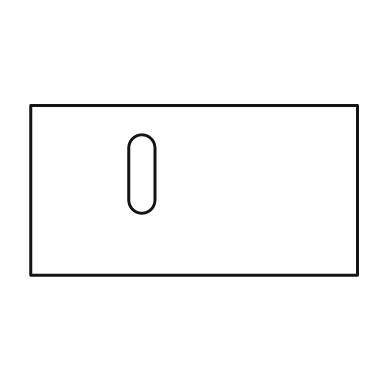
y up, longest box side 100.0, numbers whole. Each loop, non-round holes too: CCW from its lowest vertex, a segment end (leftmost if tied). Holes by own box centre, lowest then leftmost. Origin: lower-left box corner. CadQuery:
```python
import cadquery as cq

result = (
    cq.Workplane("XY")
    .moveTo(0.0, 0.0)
    .lineTo(100.0, 0.0)
    .lineTo(100.0, 52.0)
    .lineTo(0.0, 52.0)
    .close()
    .moveTo(30.0, 23.0)
    .threePointArc((34.0, 19.0), (38.0, 23.0))
    .lineTo(38.0, 39.0)
    .threePointArc((34.0, 43.0), (30.0, 39.0))
    .close()
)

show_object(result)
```